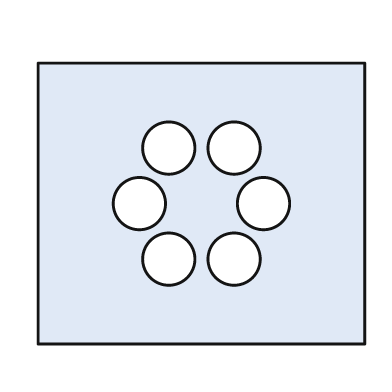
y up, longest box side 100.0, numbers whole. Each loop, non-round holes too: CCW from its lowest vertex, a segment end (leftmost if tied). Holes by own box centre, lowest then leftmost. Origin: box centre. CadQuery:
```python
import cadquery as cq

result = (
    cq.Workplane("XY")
    .moveTo(-50.0, -43.0)
    .lineTo(50.0, -43.0)
    .lineTo(50.0, 43.0)
    .lineTo(-50.0, 43.0)
    .close()
    .moveTo(-10.0, -17.0)
    .circle(8.0)
    .moveTo(10.0, -17.0)
    .circle(8.0)
    .moveTo(-19.0, 0.0)
    .circle(8.0)
    .moveTo(19.0, 0.0)
    .circle(8.0)
    .moveTo(-10.0, 17.0)
    .circle(8.0)
    .moveTo(10.0, 17.0)
    .circle(8.0)
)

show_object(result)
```